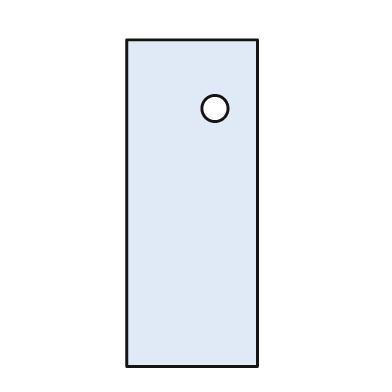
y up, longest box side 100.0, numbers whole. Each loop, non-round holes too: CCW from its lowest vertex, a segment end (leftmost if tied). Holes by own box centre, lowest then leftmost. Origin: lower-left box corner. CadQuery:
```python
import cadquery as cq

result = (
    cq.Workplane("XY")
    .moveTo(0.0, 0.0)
    .lineTo(40.0, 0.0)
    .lineTo(40.0, 100.0)
    .lineTo(0.0, 100.0)
    .close()
    .moveTo(27.0, 79.0)
    .circle(4.0)
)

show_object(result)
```